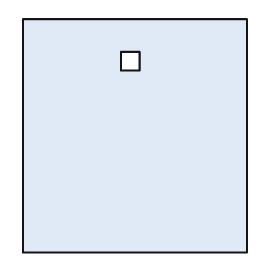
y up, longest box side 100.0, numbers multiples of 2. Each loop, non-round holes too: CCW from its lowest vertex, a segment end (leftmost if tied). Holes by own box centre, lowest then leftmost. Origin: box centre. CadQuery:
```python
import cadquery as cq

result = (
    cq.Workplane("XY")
    .moveTo(-48.0, -50.0)
    .lineTo(48.0, -50.0)
    .lineTo(48.0, 50.0)
    .lineTo(-48.0, 50.0)
    .close()
    .moveTo(-6.0, 28.0)
    .lineTo(2.0, 28.0)
    .lineTo(2.0, 36.0)
    .lineTo(-6.0, 36.0)
    .close()
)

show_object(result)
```